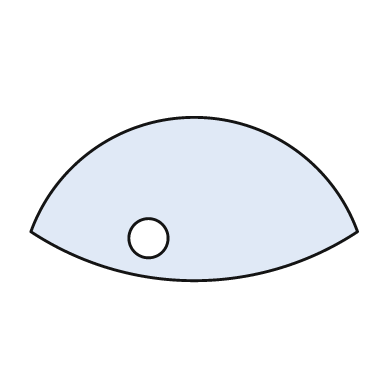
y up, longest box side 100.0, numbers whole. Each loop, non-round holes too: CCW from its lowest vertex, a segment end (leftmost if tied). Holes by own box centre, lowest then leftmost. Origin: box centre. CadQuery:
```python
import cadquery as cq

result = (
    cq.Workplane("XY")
    .moveTo(-50.0, -10.0)
    .threePointArc((0.0, -25.0), (50.0, -10.0))
    .threePointArc((0.0, 25.0), (-50.0, -10.0))
    .close()
    .moveTo(-14.0, -12.0)
    .circle(6.0)
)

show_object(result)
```